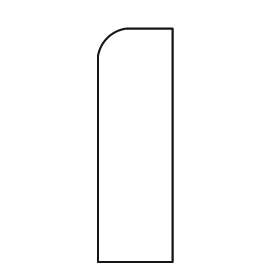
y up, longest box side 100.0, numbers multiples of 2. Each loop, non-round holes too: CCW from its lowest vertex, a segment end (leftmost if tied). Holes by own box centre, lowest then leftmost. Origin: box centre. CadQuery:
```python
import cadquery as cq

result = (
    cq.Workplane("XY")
    .moveTo(-16.0, -50.0)
    .lineTo(16.0, -50.0)
    .lineTo(16.0, 50.0)
    .lineTo(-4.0, 50.0)
    .threePointArc((-12.0, 46.0), (-16.0, 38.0))
    .close()
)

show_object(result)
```